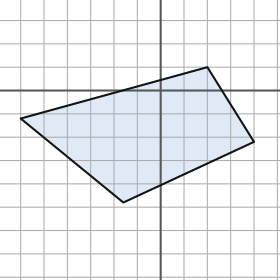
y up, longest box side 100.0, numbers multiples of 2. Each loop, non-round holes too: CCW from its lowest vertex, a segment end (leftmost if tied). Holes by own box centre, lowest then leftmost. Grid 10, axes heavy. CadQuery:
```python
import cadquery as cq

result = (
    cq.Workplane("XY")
    .moveTo(-16.0, -48.0)
    .lineTo(40.0, -22.0)
    .lineTo(20.0, 10.0)
    .lineTo(-60.0, -12.0)
    .close()
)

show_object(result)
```